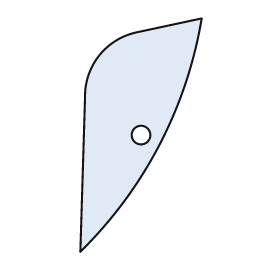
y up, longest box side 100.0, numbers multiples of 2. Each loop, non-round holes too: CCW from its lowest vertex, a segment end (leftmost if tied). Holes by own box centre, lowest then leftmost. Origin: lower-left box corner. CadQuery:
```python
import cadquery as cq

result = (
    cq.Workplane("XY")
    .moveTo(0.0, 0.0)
    .threePointArc((34.0, 46.0), (52.0, 100.0))
    .lineTo(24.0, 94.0)
    .threePointArc((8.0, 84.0), (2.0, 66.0))
    .close()
    .moveTo(26.0, 50.0)
    .circle(4.0)
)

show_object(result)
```